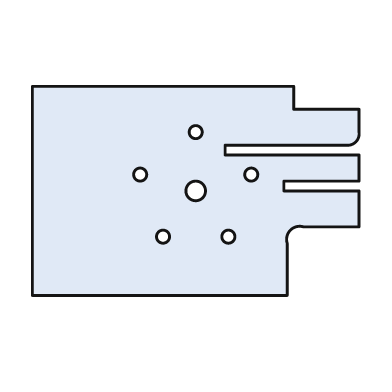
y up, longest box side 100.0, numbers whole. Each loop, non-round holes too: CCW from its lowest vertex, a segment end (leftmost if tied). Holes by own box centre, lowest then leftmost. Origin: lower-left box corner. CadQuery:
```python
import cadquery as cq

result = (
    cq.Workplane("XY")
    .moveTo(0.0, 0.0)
    .lineTo(78.0, 0.0)
    .lineTo(78.0, 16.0)
    .threePointArc((79.0, 20.0), (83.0, 21.0))
    .lineTo(100.0, 21.0)
    .lineTo(100.0, 32.0)
    .lineTo(77.0, 32.0)
    .lineTo(77.0, 35.0)
    .lineTo(100.0, 35.0)
    .lineTo(100.0, 43.0)
    .lineTo(59.0, 43.0)
    .lineTo(59.0, 46.0)
    .lineTo(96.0, 46.0)
    .threePointArc((99.0, 47.0), (100.0, 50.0))
    .lineTo(100.0, 57.0)
    .lineTo(80.0, 57.0)
    .lineTo(80.0, 64.0)
    .lineTo(0.0, 64.0)
    .close()
    .moveTo(40.0, 18.0)
    .circle(2.0)
    .moveTo(60.0, 18.0)
    .circle(2.0)
    .moveTo(50.0, 32.0)
    .circle(3.0)
    .moveTo(33.0, 37.0)
    .circle(2.0)
    .moveTo(67.0, 37.0)
    .circle(2.0)
    .moveTo(50.0, 50.0)
    .circle(2.0)
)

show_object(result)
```